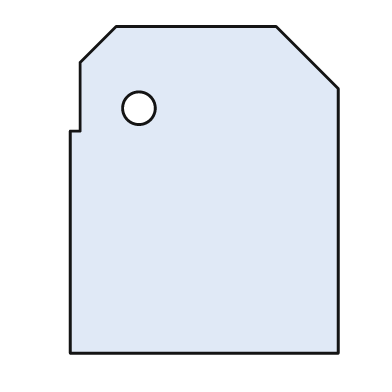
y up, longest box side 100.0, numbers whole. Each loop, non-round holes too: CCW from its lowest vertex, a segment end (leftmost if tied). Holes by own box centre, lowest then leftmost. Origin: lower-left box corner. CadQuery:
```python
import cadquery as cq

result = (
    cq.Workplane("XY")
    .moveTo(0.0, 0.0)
    .lineTo(82.0, 0.0)
    .lineTo(82.0, 81.0)
    .lineTo(63.0, 100.0)
    .lineTo(14.0, 100.0)
    .lineTo(3.0, 89.0)
    .lineTo(3.0, 68.0)
    .lineTo(0.0, 68.0)
    .close()
    .moveTo(21.0, 75.0)
    .circle(5.0)
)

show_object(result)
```